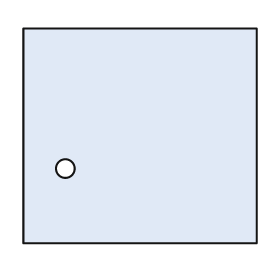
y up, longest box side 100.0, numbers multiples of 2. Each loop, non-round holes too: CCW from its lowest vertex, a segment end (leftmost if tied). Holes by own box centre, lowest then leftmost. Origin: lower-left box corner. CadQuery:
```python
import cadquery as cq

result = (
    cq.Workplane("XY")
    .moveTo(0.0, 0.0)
    .lineTo(100.0, 0.0)
    .lineTo(100.0, 92.0)
    .lineTo(0.0, 92.0)
    .close()
    .moveTo(18.0, 32.0)
    .circle(4.0)
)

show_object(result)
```